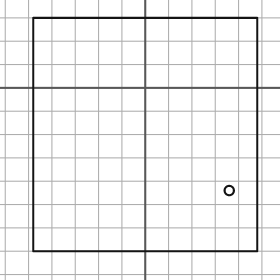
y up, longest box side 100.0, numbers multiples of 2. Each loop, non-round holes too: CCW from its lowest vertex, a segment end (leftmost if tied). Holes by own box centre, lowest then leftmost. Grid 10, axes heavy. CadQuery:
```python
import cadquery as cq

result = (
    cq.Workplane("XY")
    .moveTo(-48.0, -70.0)
    .lineTo(48.0, -70.0)
    .lineTo(48.0, 30.0)
    .lineTo(-48.0, 30.0)
    .close()
    .moveTo(36.0, -44.0)
    .circle(2.0)
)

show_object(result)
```